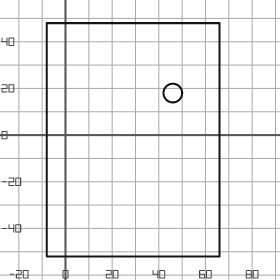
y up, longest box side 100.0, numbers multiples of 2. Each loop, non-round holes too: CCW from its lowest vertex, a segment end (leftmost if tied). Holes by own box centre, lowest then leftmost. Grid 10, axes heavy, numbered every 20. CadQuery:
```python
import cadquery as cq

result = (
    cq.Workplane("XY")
    .moveTo(-8.0, -52.0)
    .lineTo(66.0, -52.0)
    .lineTo(66.0, 48.0)
    .lineTo(-8.0, 48.0)
    .close()
    .moveTo(46.0, 18.0)
    .circle(4.0)
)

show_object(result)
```